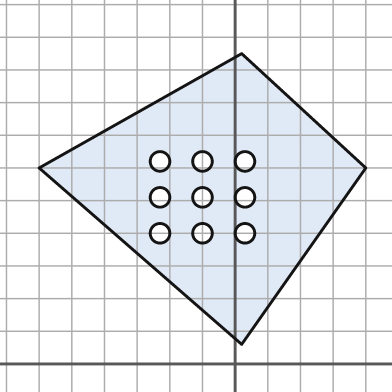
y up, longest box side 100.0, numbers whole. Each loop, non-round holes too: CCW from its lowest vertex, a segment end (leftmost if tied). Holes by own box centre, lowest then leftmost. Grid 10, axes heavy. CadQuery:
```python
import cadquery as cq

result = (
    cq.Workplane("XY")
    .moveTo(2.0, 6.0)
    .lineTo(40.0, 60.0)
    .lineTo(2.0, 95.0)
    .lineTo(-60.0, 60.0)
    .close()
    .moveTo(-23.0, 40.0)
    .circle(3.0)
    .moveTo(-10.0, 40.0)
    .circle(3.0)
    .moveTo(3.0, 40.0)
    .circle(3.0)
    .moveTo(-23.0, 51.0)
    .circle(3.0)
    .moveTo(-10.0, 51.0)
    .circle(3.0)
    .moveTo(3.0, 51.0)
    .circle(3.0)
    .moveTo(-23.0, 62.0)
    .circle(3.0)
    .moveTo(-10.0, 62.0)
    .circle(3.0)
    .moveTo(3.0, 62.0)
    .circle(3.0)
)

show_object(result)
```